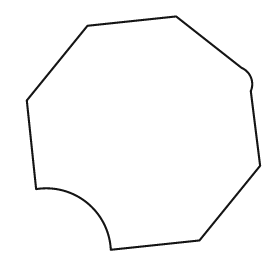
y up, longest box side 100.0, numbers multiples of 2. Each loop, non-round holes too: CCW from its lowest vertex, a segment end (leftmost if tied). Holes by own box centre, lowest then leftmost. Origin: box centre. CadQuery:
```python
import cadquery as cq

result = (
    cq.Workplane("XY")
    .moveTo(-14.0, -50.0)
    .lineTo(24.0, -46.0)
    .lineTo(50.0, -14.0)
    .lineTo(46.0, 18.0)
    .threePointArc((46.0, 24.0), (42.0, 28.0))
    .lineTo(14.0, 50.0)
    .lineTo(-24.0, 46.0)
    .lineTo(-50.0, 14.0)
    .lineTo(-46.0, -24.0)
    .threePointArc((-24.0, -30.0), (-14.0, -50.0))
    .close()
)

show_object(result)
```